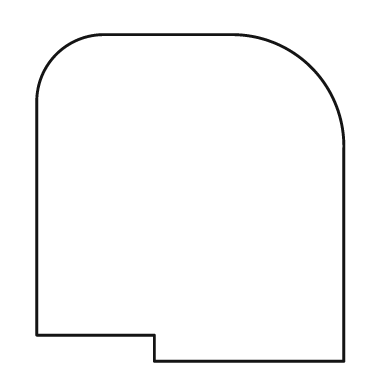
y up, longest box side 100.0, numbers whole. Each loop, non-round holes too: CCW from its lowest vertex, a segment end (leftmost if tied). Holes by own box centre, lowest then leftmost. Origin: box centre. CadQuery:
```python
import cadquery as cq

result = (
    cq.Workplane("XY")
    .moveTo(-11.0, -50.0)
    .lineTo(47.0, -50.0)
    .lineTo(47.0, 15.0)
    .threePointArc((37.0, 40.0), (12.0, 50.0))
    .lineTo(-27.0, 50.0)
    .threePointArc((-41.0, 44.0), (-47.0, 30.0))
    .lineTo(-47.0, -42.0)
    .lineTo(-11.0, -42.0)
    .close()
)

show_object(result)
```